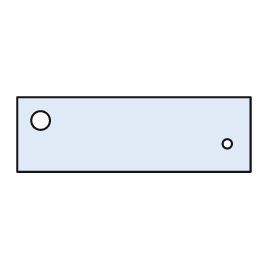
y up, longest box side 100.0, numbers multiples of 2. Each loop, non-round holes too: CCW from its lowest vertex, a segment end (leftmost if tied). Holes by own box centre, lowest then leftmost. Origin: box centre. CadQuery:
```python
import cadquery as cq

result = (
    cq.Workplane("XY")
    .moveTo(-50.0, -16.0)
    .lineTo(50.0, -16.0)
    .lineTo(50.0, 16.0)
    .lineTo(-50.0, 16.0)
    .close()
    .moveTo(40.0, -4.0)
    .circle(2.0)
    .moveTo(-40.0, 6.0)
    .circle(4.0)
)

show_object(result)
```